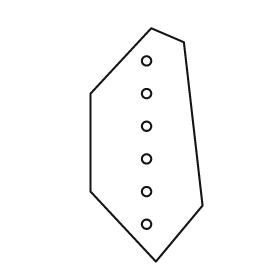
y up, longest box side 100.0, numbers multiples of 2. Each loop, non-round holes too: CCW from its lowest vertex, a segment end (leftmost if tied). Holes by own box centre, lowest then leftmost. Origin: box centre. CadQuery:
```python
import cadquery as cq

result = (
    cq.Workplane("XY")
    .moveTo(4.0, -50.0)
    .lineTo(24.0, -26.0)
    .lineTo(16.0, 44.0)
    .lineTo(2.0, 50.0)
    .lineTo(-24.0, 22.0)
    .lineTo(-24.0, -20.0)
    .close()
    .moveTo(0.0, -34.0)
    .circle(2.0)
    .moveTo(0.0, -20.0)
    .circle(2.0)
    .moveTo(0.0, -6.0)
    .circle(2.0)
    .moveTo(0.0, 8.0)
    .circle(2.0)
    .moveTo(0.0, 22.0)
    .circle(2.0)
    .moveTo(0.0, 36.0)
    .circle(2.0)
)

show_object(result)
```